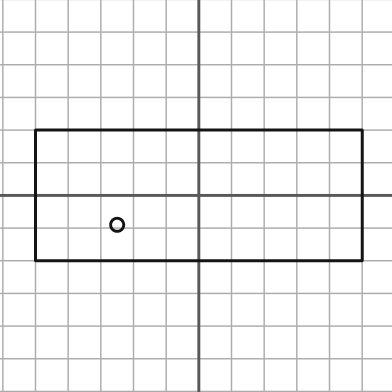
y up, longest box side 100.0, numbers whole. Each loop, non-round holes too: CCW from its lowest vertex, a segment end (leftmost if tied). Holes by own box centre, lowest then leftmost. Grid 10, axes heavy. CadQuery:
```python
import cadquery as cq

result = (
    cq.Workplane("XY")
    .moveTo(-50.0, -20.0)
    .lineTo(50.0, -20.0)
    .lineTo(50.0, 20.0)
    .lineTo(-50.0, 20.0)
    .close()
    .moveTo(-25.0, -9.0)
    .circle(2.0)
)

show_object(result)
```